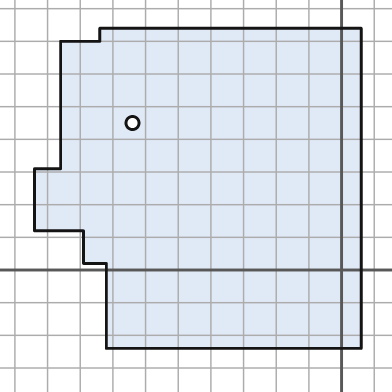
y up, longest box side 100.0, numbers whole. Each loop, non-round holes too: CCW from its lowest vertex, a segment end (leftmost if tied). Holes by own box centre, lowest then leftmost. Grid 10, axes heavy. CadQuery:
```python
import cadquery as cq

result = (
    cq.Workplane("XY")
    .moveTo(-72.0, -24.0)
    .lineTo(6.0, -24.0)
    .lineTo(6.0, 74.0)
    .lineTo(-74.0, 74.0)
    .lineTo(-74.0, 70.0)
    .lineTo(-86.0, 70.0)
    .lineTo(-86.0, 31.0)
    .lineTo(-94.0, 31.0)
    .lineTo(-94.0, 12.0)
    .lineTo(-79.0, 12.0)
    .lineTo(-79.0, 2.0)
    .lineTo(-72.0, 2.0)
    .close()
    .moveTo(-64.0, 45.0)
    .circle(2.0)
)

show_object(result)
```